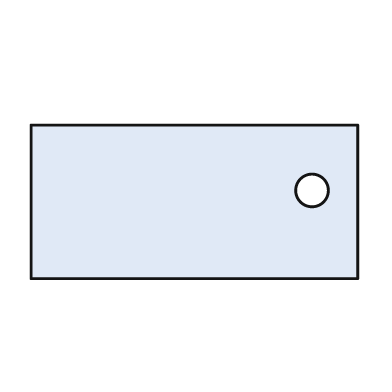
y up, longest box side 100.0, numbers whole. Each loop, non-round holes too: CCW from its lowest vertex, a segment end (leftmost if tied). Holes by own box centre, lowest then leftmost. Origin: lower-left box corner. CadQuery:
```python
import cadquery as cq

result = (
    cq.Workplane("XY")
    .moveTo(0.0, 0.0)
    .lineTo(100.0, 0.0)
    .lineTo(100.0, 47.0)
    .lineTo(0.0, 47.0)
    .close()
    .moveTo(86.0, 27.0)
    .circle(5.0)
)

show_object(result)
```